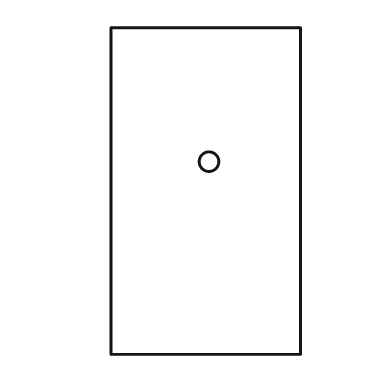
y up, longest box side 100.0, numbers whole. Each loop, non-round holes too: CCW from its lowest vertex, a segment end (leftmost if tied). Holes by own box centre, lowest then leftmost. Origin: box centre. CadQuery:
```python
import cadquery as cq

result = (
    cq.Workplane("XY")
    .moveTo(-29.0, -50.0)
    .lineTo(29.0, -50.0)
    .lineTo(29.0, 50.0)
    .lineTo(-29.0, 50.0)
    .close()
    .moveTo(1.0, 9.0)
    .circle(3.0)
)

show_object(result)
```